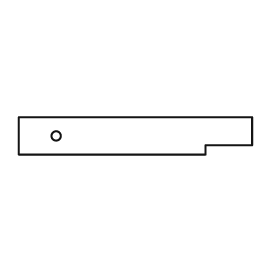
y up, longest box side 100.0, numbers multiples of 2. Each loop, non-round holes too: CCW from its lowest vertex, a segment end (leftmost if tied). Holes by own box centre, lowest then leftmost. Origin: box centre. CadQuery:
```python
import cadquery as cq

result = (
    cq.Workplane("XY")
    .moveTo(-50.0, -8.0)
    .lineTo(30.0, -8.0)
    .lineTo(30.0, -4.0)
    .lineTo(50.0, -4.0)
    .lineTo(50.0, 8.0)
    .lineTo(-50.0, 8.0)
    .close()
    .moveTo(-34.0, 0.0)
    .circle(2.0)
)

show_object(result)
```